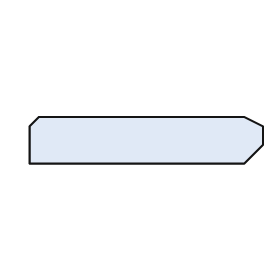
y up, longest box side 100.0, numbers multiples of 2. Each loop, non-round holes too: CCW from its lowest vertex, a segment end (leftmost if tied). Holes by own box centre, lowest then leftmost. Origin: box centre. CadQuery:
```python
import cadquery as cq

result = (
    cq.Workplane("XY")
    .moveTo(-50.0, -10.0)
    .lineTo(42.0, -10.0)
    .lineTo(50.0, -2.0)
    .lineTo(50.0, 6.0)
    .lineTo(42.0, 10.0)
    .lineTo(-46.0, 10.0)
    .lineTo(-50.0, 6.0)
    .close()
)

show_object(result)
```